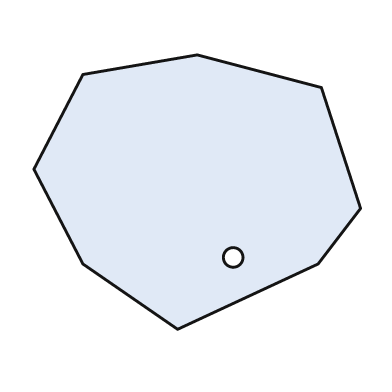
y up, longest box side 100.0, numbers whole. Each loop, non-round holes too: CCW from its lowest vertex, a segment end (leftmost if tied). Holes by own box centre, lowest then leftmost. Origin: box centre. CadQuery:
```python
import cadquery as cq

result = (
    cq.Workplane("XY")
    .moveTo(-6.0, -42.0)
    .lineTo(37.0, -22.0)
    .lineTo(50.0, -5.0)
    .lineTo(38.0, 32.0)
    .lineTo(0.0, 42.0)
    .lineTo(-35.0, 36.0)
    .lineTo(-50.0, 7.0)
    .lineTo(-35.0, -22.0)
    .close()
    .moveTo(11.0, -20.0)
    .circle(3.0)
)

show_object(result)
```